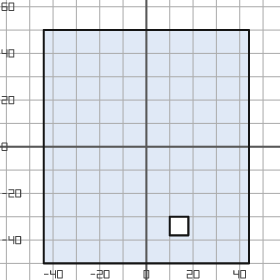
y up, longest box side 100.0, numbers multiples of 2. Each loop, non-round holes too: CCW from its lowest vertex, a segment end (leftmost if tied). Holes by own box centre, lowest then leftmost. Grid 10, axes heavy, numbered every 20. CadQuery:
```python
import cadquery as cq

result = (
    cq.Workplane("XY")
    .moveTo(-44.0, -50.0)
    .lineTo(44.0, -50.0)
    .lineTo(44.0, 50.0)
    .lineTo(-44.0, 50.0)
    .close()
    .moveTo(10.0, -38.0)
    .lineTo(18.0, -38.0)
    .lineTo(18.0, -30.0)
    .lineTo(10.0, -30.0)
    .close()
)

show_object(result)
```